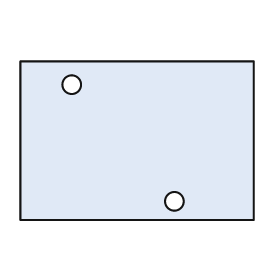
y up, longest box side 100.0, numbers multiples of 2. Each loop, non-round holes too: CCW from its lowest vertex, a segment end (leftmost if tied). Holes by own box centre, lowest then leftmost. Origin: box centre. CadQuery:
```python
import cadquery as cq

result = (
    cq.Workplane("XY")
    .moveTo(-50.0, -34.0)
    .lineTo(50.0, -34.0)
    .lineTo(50.0, 34.0)
    .lineTo(-50.0, 34.0)
    .close()
    .moveTo(16.0, -26.0)
    .circle(4.0)
    .moveTo(-28.0, 24.0)
    .circle(4.0)
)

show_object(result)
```